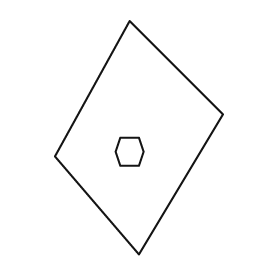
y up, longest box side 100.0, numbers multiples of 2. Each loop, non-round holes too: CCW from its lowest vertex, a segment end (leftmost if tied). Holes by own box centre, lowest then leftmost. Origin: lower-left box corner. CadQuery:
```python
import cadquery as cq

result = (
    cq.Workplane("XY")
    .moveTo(36.0, 0.0)
    .lineTo(72.0, 60.0)
    .lineTo(32.0, 100.0)
    .lineTo(0.0, 42.0)
    .close()
    .moveTo(28.0, 38.0)
    .lineTo(36.0, 38.0)
    .lineTo(38.0, 44.0)
    .lineTo(36.0, 50.0)
    .lineTo(28.0, 50.0)
    .lineTo(26.0, 44.0)
    .close()
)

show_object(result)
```